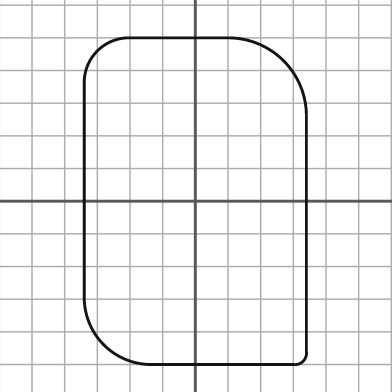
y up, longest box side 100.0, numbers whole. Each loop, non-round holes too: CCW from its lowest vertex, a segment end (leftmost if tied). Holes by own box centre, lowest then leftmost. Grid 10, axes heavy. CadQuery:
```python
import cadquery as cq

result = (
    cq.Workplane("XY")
    .moveTo(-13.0, -50.0)
    .lineTo(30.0, -50.0)
    .threePointArc((33.0, -49.0), (34.0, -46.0))
    .lineTo(34.0, 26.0)
    .threePointArc((27.0, 43.0), (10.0, 50.0))
    .lineTo(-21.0, 50.0)
    .threePointArc((-30.0, 46.0), (-34.0, 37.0))
    .lineTo(-34.0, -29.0)
    .threePointArc((-28.0, -44.0), (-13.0, -50.0))
    .close()
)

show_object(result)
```